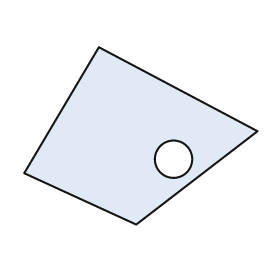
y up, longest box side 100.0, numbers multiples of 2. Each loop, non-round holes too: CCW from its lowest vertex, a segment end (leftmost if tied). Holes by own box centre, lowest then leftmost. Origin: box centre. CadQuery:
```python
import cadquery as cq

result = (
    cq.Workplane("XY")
    .moveTo(-2.0, -38.0)
    .lineTo(50.0, 2.0)
    .lineTo(-18.0, 38.0)
    .lineTo(-50.0, -16.0)
    .close()
    .moveTo(14.0, -10.0)
    .circle(8.0)
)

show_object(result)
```